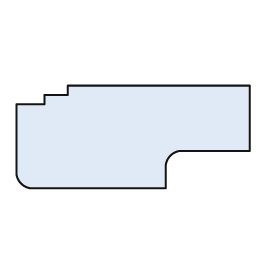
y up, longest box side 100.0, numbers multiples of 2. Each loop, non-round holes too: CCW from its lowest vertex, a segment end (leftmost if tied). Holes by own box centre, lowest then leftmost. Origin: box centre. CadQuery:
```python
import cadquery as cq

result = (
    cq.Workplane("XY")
    .moveTo(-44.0, -22.0)
    .lineTo(14.0, -22.0)
    .lineTo(14.0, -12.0)
    .threePointArc((16.0, -8.0), (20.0, -6.0))
    .lineTo(50.0, -6.0)
    .lineTo(50.0, 22.0)
    .lineTo(-28.0, 22.0)
    .lineTo(-28.0, 18.0)
    .lineTo(-38.0, 18.0)
    .lineTo(-38.0, 14.0)
    .lineTo(-50.0, 14.0)
    .lineTo(-50.0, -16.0)
    .threePointArc((-48.0, -20.0), (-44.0, -22.0))
    .close()
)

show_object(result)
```